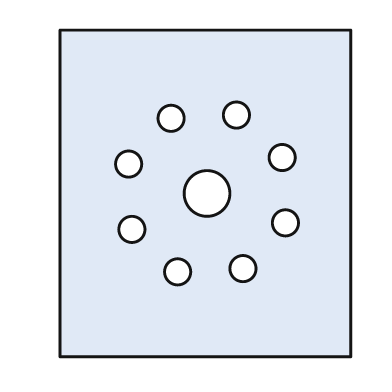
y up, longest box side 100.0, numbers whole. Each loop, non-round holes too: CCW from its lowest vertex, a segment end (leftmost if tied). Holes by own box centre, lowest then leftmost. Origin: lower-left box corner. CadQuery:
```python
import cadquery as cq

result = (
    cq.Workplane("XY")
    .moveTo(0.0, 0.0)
    .lineTo(89.0, 0.0)
    .lineTo(89.0, 100.0)
    .lineTo(0.0, 100.0)
    .close()
    .moveTo(36.0, 26.0)
    .circle(4.0)
    .moveTo(56.0, 27.0)
    .circle(4.0)
    .moveTo(22.0, 39.0)
    .circle(4.0)
    .moveTo(69.0, 41.0)
    .circle(4.0)
    .moveTo(45.0, 50.0)
    .circle(7.0)
    .moveTo(21.0, 59.0)
    .circle(4.0)
    .moveTo(68.0, 61.0)
    .circle(4.0)
    .moveTo(34.0, 73.0)
    .circle(4.0)
    .moveTo(54.0, 74.0)
    .circle(4.0)
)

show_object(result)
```